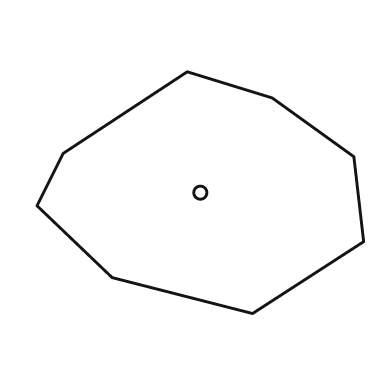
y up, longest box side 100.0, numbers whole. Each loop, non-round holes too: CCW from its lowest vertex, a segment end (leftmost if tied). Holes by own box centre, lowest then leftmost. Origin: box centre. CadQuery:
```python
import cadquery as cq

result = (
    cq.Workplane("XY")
    .moveTo(16.0, -37.0)
    .lineTo(50.0, -15.0)
    .lineTo(47.0, 11.0)
    .lineTo(22.0, 29.0)
    .lineTo(-4.0, 37.0)
    .lineTo(-42.0, 12.0)
    .lineTo(-50.0, -4.0)
    .lineTo(-27.0, -26.0)
    .close()
    .moveTo(0.0, 0.0)
    .circle(2.0)
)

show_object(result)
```